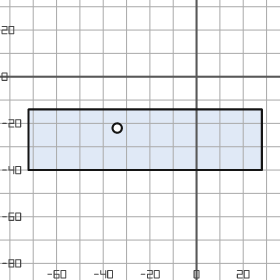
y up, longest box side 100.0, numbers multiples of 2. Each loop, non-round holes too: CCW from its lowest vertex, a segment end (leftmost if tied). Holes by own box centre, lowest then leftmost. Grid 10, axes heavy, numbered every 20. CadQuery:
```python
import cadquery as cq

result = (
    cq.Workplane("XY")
    .moveTo(-72.0, -40.0)
    .lineTo(28.0, -40.0)
    .lineTo(28.0, -14.0)
    .lineTo(-72.0, -14.0)
    .close()
    .moveTo(-34.0, -22.0)
    .circle(2.0)
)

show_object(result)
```